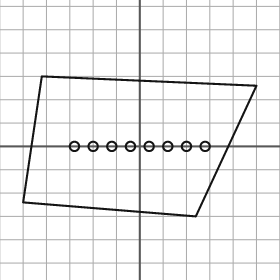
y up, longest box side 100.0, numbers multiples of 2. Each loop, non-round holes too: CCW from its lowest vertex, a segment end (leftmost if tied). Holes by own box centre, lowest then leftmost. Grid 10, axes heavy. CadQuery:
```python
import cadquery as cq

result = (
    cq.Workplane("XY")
    .moveTo(24.0, -30.0)
    .lineTo(50.0, 26.0)
    .lineTo(-42.0, 30.0)
    .lineTo(-50.0, -24.0)
    .close()
    .moveTo(-28.0, 0.0)
    .circle(2.0)
    .moveTo(-20.0, 0.0)
    .circle(2.0)
    .moveTo(-12.0, 0.0)
    .circle(2.0)
    .moveTo(-4.0, 0.0)
    .circle(2.0)
    .moveTo(4.0, 0.0)
    .circle(2.0)
    .moveTo(12.0, 0.0)
    .circle(2.0)
    .moveTo(20.0, 0.0)
    .circle(2.0)
    .moveTo(28.0, 0.0)
    .circle(2.0)
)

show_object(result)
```